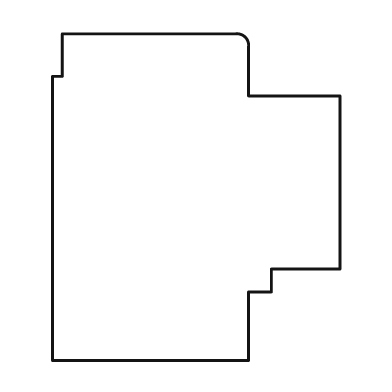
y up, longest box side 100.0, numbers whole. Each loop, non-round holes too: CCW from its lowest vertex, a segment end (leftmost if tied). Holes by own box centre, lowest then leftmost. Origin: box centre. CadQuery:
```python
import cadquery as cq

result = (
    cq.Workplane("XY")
    .moveTo(-44.0, -50.0)
    .lineTo(16.0, -50.0)
    .lineTo(16.0, -29.0)
    .lineTo(23.0, -29.0)
    .lineTo(23.0, -22.0)
    .lineTo(44.0, -22.0)
    .lineTo(44.0, 31.0)
    .lineTo(16.0, 31.0)
    .lineTo(16.0, 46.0)
    .threePointArc((15.0, 49.0), (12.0, 50.0))
    .lineTo(-41.0, 50.0)
    .lineTo(-41.0, 37.0)
    .lineTo(-44.0, 37.0)
    .close()
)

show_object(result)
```